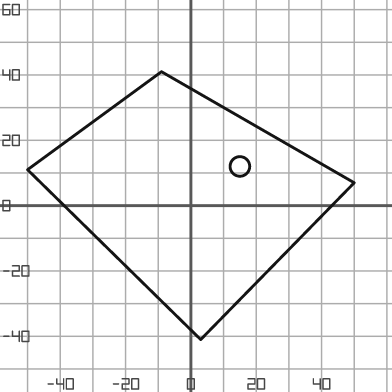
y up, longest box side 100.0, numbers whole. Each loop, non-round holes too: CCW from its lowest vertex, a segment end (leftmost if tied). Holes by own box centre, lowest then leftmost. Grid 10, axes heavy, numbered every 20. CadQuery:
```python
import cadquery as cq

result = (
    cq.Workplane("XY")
    .moveTo(3.0, -41.0)
    .lineTo(50.0, 7.0)
    .lineTo(-9.0, 41.0)
    .lineTo(-50.0, 11.0)
    .close()
    .moveTo(15.0, 12.0)
    .circle(3.0)
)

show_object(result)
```